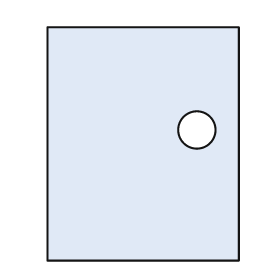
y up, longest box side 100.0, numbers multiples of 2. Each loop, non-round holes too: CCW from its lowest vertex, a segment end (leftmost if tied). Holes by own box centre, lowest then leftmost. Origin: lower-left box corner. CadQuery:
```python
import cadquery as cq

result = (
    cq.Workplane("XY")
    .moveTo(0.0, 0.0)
    .lineTo(82.0, 0.0)
    .lineTo(82.0, 100.0)
    .lineTo(0.0, 100.0)
    .close()
    .moveTo(64.0, 56.0)
    .circle(8.0)
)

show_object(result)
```